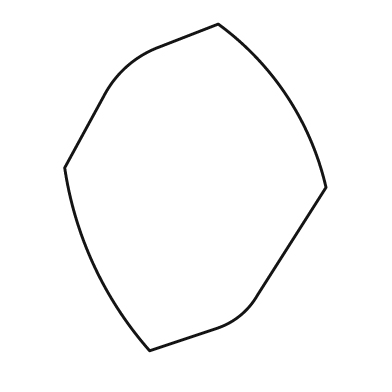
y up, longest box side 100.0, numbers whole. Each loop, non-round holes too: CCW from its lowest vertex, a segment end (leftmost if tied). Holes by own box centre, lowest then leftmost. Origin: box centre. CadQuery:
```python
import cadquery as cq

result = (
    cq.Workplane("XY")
    .moveTo(-14.0, -50.0)
    .lineTo(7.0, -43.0)
    .threePointArc((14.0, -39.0), (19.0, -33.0))
    .lineTo(40.0, 0.0)
    .threePointArc((28.0, 28.0), (7.0, 50.0))
    .lineTo(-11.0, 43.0)
    .threePointArc((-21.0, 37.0), (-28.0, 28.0))
    .lineTo(-40.0, 6.0)
    .threePointArc((-31.0, -24.0), (-14.0, -50.0))
    .close()
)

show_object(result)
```